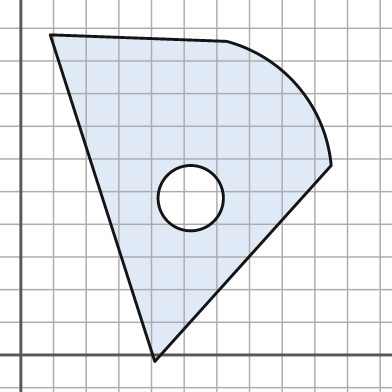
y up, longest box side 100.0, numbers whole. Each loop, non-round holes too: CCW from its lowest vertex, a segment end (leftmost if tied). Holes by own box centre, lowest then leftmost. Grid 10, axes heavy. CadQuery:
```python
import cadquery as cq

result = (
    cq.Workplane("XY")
    .moveTo(41.0, -2.0)
    .lineTo(95.0, 58.0)
    .threePointArc((85.0, 82.0), (63.0, 96.0))
    .lineTo(9.0, 98.0)
    .close()
    .moveTo(52.0, 48.0)
    .circle(10.0)
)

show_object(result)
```